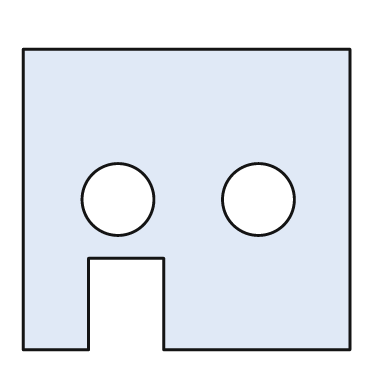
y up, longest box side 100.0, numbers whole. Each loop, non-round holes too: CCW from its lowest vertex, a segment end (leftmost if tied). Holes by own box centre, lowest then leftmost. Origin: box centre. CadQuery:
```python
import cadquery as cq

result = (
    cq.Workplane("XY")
    .moveTo(-50.0, -46.0)
    .lineTo(-30.0, -46.0)
    .lineTo(-30.0, -18.0)
    .lineTo(-7.0, -18.0)
    .lineTo(-7.0, -46.0)
    .lineTo(50.0, -46.0)
    .lineTo(50.0, 46.0)
    .lineTo(-50.0, 46.0)
    .close()
    .moveTo(-21.0, 0.0)
    .circle(11.0)
    .moveTo(22.0, 0.0)
    .circle(11.0)
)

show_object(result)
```